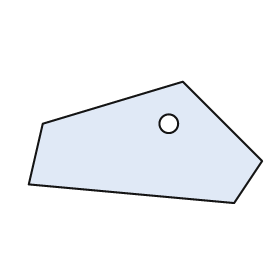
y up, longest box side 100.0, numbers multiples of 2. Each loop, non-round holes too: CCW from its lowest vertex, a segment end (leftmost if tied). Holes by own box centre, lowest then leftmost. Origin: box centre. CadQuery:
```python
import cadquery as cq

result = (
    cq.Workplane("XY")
    .moveTo(38.0, -26.0)
    .lineTo(50.0, -8.0)
    .lineTo(16.0, 26.0)
    .lineTo(-44.0, 8.0)
    .lineTo(-50.0, -18.0)
    .close()
    .moveTo(10.0, 8.0)
    .circle(4.0)
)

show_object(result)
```